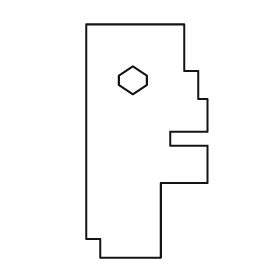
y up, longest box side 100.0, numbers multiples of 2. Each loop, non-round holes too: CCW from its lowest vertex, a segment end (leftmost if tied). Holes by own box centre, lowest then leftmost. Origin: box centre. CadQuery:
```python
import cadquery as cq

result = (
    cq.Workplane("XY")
    .moveTo(-20.0, -50.0)
    .lineTo(6.0, -50.0)
    .lineTo(6.0, -18.0)
    .lineTo(26.0, -18.0)
    .lineTo(26.0, -2.0)
    .lineTo(10.0, -2.0)
    .lineTo(10.0, 4.0)
    .lineTo(26.0, 4.0)
    .lineTo(26.0, 18.0)
    .lineTo(22.0, 18.0)
    .lineTo(22.0, 30.0)
    .lineTo(16.0, 30.0)
    .lineTo(16.0, 50.0)
    .lineTo(-26.0, 50.0)
    .lineTo(-26.0, -42.0)
    .lineTo(-20.0, -42.0)
    .close()
    .moveTo(-6.0, 20.0)
    .lineTo(0.0, 24.0)
    .lineTo(0.0, 28.0)
    .lineTo(-6.0, 32.0)
    .lineTo(-12.0, 28.0)
    .lineTo(-12.0, 24.0)
    .close()
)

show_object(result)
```